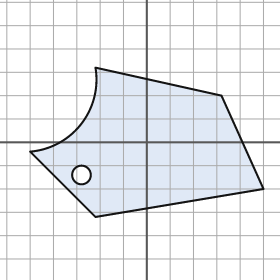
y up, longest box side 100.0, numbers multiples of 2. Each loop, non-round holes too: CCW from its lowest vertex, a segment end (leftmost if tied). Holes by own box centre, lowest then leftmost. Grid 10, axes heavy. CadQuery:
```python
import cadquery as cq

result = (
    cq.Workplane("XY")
    .moveTo(-22.0, -32.0)
    .lineTo(50.0, -20.0)
    .lineTo(32.0, 20.0)
    .lineTo(-22.0, 32.0)
    .threePointArc((-28.0, 8.0), (-50.0, -4.0))
    .close()
    .moveTo(-28.0, -14.0)
    .circle(4.0)
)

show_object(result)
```